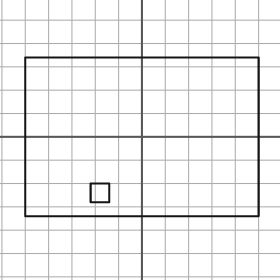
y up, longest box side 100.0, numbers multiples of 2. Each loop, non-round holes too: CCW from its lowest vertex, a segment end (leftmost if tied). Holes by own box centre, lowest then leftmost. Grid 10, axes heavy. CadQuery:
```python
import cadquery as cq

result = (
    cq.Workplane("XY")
    .moveTo(-50.0, -34.0)
    .lineTo(50.0, -34.0)
    .lineTo(50.0, 34.0)
    .lineTo(-50.0, 34.0)
    .close()
    .moveTo(-22.0, -28.0)
    .lineTo(-14.0, -28.0)
    .lineTo(-14.0, -20.0)
    .lineTo(-22.0, -20.0)
    .close()
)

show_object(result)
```